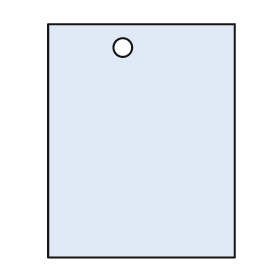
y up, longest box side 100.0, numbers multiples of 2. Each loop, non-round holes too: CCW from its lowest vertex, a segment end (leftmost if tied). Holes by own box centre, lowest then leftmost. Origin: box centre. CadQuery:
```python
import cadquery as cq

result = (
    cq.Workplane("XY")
    .moveTo(-40.0, -50.0)
    .lineTo(40.0, -50.0)
    .lineTo(40.0, 50.0)
    .lineTo(-40.0, 50.0)
    .close()
    .moveTo(-8.0, 40.0)
    .circle(4.0)
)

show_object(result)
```